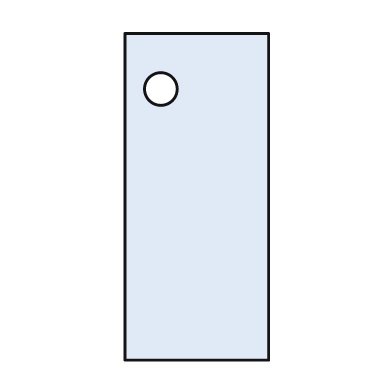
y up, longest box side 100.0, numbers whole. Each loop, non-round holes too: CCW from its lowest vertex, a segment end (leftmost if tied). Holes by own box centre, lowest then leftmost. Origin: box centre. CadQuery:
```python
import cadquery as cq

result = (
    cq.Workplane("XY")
    .moveTo(-22.0, -50.0)
    .lineTo(22.0, -50.0)
    .lineTo(22.0, 50.0)
    .lineTo(-22.0, 50.0)
    .close()
    .moveTo(-11.0, 33.0)
    .circle(5.0)
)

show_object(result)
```